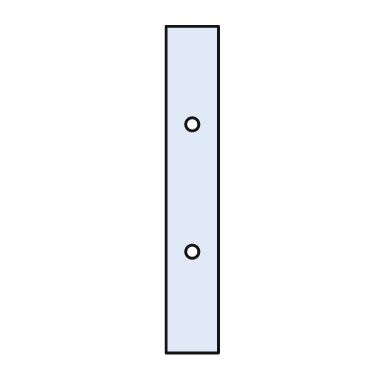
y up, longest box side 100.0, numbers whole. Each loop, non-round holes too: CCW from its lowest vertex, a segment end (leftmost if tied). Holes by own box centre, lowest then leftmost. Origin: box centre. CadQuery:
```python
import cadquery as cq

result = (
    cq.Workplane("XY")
    .moveTo(-8.0, -50.0)
    .lineTo(8.0, -50.0)
    .lineTo(8.0, 50.0)
    .lineTo(-8.0, 50.0)
    .close()
    .moveTo(0.0, -19.0)
    .circle(2.0)
    .moveTo(0.0, 20.0)
    .circle(2.0)
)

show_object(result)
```